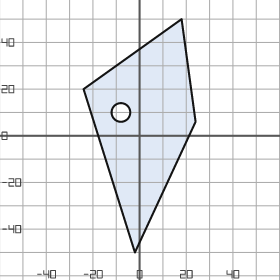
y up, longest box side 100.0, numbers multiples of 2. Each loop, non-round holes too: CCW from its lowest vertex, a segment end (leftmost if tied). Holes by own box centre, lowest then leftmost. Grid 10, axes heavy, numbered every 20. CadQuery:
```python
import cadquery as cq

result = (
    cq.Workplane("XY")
    .moveTo(-2.0, -50.0)
    .lineTo(24.0, 6.0)
    .lineTo(18.0, 50.0)
    .lineTo(-24.0, 20.0)
    .close()
    .moveTo(-8.0, 10.0)
    .circle(4.0)
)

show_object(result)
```